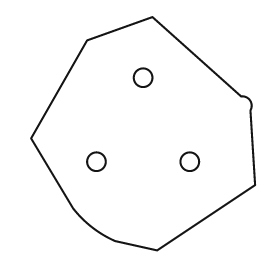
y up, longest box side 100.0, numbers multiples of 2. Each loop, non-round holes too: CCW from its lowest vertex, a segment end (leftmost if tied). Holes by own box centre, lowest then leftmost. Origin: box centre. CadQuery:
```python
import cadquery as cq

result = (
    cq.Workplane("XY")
    .moveTo(6.0, -50.0)
    .lineTo(48.0, -22.0)
    .lineTo(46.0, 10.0)
    .threePointArc((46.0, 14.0), (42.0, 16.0))
    .lineTo(4.0, 50.0)
    .lineTo(-24.0, 40.0)
    .lineTo(-48.0, -2.0)
    .lineTo(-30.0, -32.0)
    .threePointArc((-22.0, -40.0), (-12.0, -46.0))
    .close()
    .moveTo(-20.0, -12.0)
    .circle(4.0)
    .moveTo(20.0, -12.0)
    .circle(4.0)
    .moveTo(0.0, 24.0)
    .circle(4.0)
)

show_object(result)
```